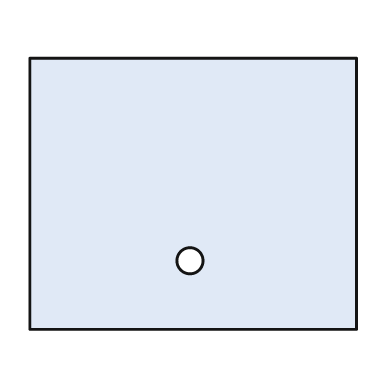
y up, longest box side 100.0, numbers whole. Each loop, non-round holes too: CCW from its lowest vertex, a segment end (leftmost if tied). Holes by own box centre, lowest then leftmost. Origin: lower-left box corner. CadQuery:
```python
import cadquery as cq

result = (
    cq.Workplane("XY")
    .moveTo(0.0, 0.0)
    .lineTo(100.0, 0.0)
    .lineTo(100.0, 83.0)
    .lineTo(0.0, 83.0)
    .close()
    .moveTo(49.0, 21.0)
    .circle(4.0)
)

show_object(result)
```